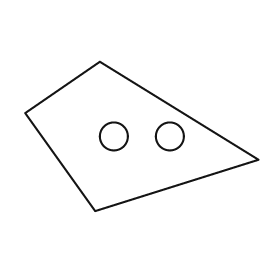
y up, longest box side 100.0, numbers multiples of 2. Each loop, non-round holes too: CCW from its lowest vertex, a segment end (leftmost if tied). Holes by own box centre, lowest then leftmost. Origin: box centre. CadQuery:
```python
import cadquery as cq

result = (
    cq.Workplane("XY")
    .moveTo(-20.0, -32.0)
    .lineTo(50.0, -10.0)
    .lineTo(-18.0, 32.0)
    .lineTo(-50.0, 10.0)
    .close()
    .moveTo(-12.0, 0.0)
    .circle(6.0)
    .moveTo(12.0, 0.0)
    .circle(6.0)
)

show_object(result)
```